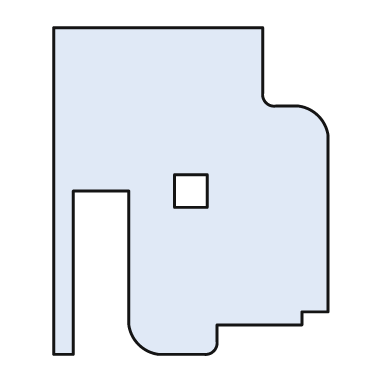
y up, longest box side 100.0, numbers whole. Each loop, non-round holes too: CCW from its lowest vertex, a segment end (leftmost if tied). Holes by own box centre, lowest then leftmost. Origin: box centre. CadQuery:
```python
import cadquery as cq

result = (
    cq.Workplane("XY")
    .moveTo(-42.0, -50.0)
    .lineTo(-36.0, -50.0)
    .lineTo(-36.0, 0.0)
    .lineTo(-19.0, 0.0)
    .lineTo(-19.0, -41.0)
    .threePointArc((-16.0, -47.0), (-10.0, -50.0))
    .lineTo(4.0, -50.0)
    .threePointArc((7.0, -49.0), (8.0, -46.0))
    .lineTo(8.0, -41.0)
    .lineTo(34.0, -41.0)
    .lineTo(34.0, -37.0)
    .lineTo(42.0, -37.0)
    .lineTo(42.0, 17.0)
    .threePointArc((39.0, 23.0), (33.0, 26.0))
    .lineTo(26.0, 26.0)
    .threePointArc((23.0, 27.0), (22.0, 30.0))
    .lineTo(22.0, 50.0)
    .lineTo(-42.0, 50.0)
    .close()
    .moveTo(-5.0, -5.0)
    .lineTo(5.0, -5.0)
    .lineTo(5.0, 5.0)
    .lineTo(-5.0, 5.0)
    .close()
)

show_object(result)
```